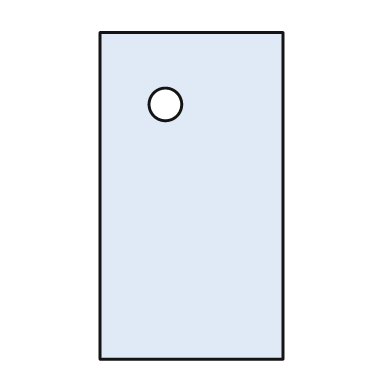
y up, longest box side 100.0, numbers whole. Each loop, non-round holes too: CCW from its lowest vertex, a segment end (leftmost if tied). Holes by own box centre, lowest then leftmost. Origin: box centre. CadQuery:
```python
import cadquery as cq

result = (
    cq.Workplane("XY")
    .moveTo(-28.0, -50.0)
    .lineTo(28.0, -50.0)
    .lineTo(28.0, 50.0)
    .lineTo(-28.0, 50.0)
    .close()
    .moveTo(-8.0, 28.0)
    .circle(5.0)
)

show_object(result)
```